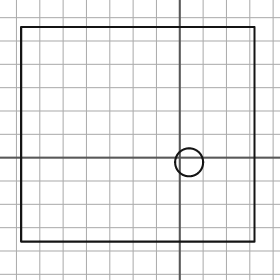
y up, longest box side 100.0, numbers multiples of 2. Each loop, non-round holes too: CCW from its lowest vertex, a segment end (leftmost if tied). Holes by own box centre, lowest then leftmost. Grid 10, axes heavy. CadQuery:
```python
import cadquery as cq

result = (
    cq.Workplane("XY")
    .moveTo(-68.0, -36.0)
    .lineTo(32.0, -36.0)
    .lineTo(32.0, 56.0)
    .lineTo(-68.0, 56.0)
    .close()
    .moveTo(4.0, -2.0)
    .circle(6.0)
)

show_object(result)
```